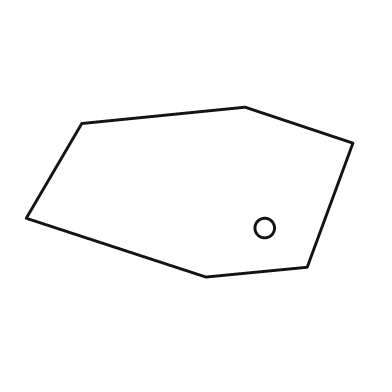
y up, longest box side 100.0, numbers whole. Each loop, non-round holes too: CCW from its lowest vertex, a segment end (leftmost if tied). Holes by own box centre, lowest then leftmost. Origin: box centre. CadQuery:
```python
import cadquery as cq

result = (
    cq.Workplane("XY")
    .moveTo(5.0, -26.0)
    .lineTo(36.0, -23.0)
    .lineTo(50.0, 15.0)
    .lineTo(17.0, 26.0)
    .lineTo(-33.0, 21.0)
    .lineTo(-50.0, -8.0)
    .close()
    .moveTo(23.0, -11.0)
    .circle(3.0)
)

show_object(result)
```